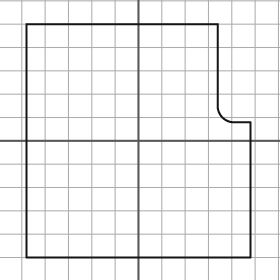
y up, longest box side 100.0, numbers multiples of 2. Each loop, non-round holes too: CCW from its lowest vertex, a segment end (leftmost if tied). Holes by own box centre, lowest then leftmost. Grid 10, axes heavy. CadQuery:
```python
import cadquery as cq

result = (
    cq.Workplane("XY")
    .moveTo(-48.0, -50.0)
    .lineTo(48.0, -50.0)
    .lineTo(48.0, 8.0)
    .lineTo(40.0, 8.0)
    .threePointArc((36.0, 10.0), (34.0, 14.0))
    .lineTo(34.0, 50.0)
    .lineTo(-48.0, 50.0)
    .close()
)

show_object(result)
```